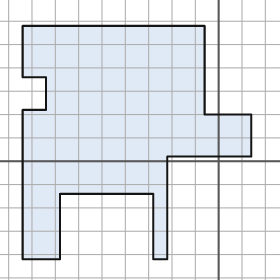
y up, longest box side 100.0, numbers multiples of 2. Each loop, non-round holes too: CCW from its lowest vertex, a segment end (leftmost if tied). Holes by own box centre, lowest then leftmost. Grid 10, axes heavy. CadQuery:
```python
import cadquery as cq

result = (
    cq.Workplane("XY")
    .moveTo(-84.0, -42.0)
    .lineTo(-68.0, -42.0)
    .lineTo(-68.0, -14.0)
    .lineTo(-28.0, -14.0)
    .lineTo(-28.0, -42.0)
    .lineTo(-22.0, -42.0)
    .lineTo(-22.0, 2.0)
    .lineTo(14.0, 2.0)
    .lineTo(14.0, 20.0)
    .lineTo(-6.0, 20.0)
    .lineTo(-6.0, 58.0)
    .lineTo(-84.0, 58.0)
    .lineTo(-84.0, 36.0)
    .lineTo(-74.0, 36.0)
    .lineTo(-74.0, 22.0)
    .lineTo(-84.0, 22.0)
    .close()
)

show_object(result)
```